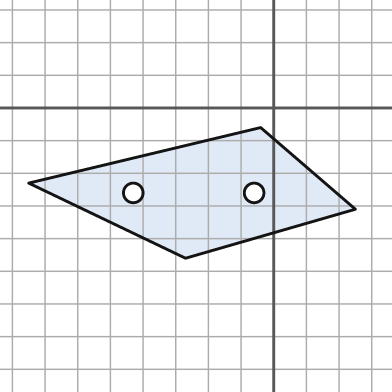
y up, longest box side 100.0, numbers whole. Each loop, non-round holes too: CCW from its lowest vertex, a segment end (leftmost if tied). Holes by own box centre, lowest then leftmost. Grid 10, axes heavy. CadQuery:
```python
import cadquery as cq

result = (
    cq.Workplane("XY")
    .moveTo(-27.0, -46.0)
    .lineTo(25.0, -31.0)
    .lineTo(-4.0, -6.0)
    .lineTo(-75.0, -23.0)
    .close()
    .moveTo(-43.0, -26.0)
    .circle(3.0)
    .moveTo(-6.0, -26.0)
    .circle(3.0)
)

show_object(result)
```